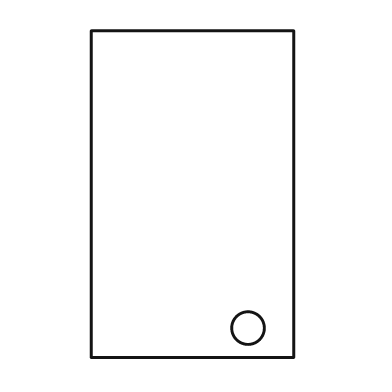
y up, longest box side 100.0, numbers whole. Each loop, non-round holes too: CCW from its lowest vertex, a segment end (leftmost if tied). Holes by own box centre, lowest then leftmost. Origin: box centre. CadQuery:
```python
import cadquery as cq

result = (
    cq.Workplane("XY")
    .moveTo(-31.0, -50.0)
    .lineTo(31.0, -50.0)
    .lineTo(31.0, 50.0)
    .lineTo(-31.0, 50.0)
    .close()
    .moveTo(17.0, -41.0)
    .circle(5.0)
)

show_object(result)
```